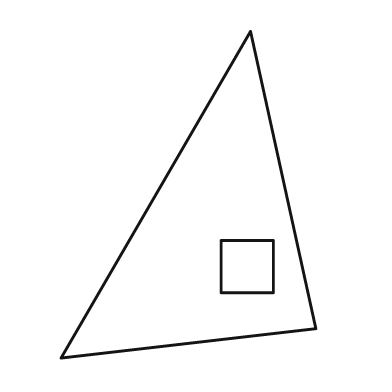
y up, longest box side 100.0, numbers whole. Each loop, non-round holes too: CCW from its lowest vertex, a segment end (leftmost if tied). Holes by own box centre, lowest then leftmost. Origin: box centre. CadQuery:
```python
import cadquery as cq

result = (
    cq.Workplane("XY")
    .moveTo(-39.0, -50.0)
    .lineTo(39.0, -41.0)
    .lineTo(19.0, 50.0)
    .close()
    .moveTo(10.0, -30.0)
    .lineTo(26.0, -30.0)
    .lineTo(26.0, -14.0)
    .lineTo(10.0, -14.0)
    .close()
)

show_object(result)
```